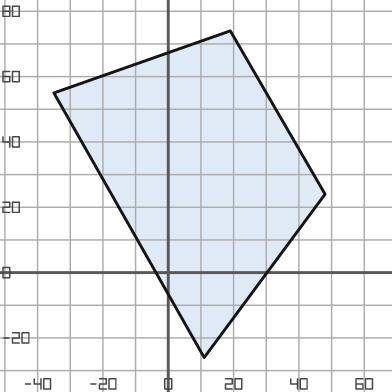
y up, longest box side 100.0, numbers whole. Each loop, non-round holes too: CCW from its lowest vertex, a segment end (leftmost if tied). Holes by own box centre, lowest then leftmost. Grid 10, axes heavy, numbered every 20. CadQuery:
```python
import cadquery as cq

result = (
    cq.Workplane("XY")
    .moveTo(11.0, -26.0)
    .lineTo(48.0, 24.0)
    .lineTo(19.0, 74.0)
    .lineTo(-35.0, 55.0)
    .close()
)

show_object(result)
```